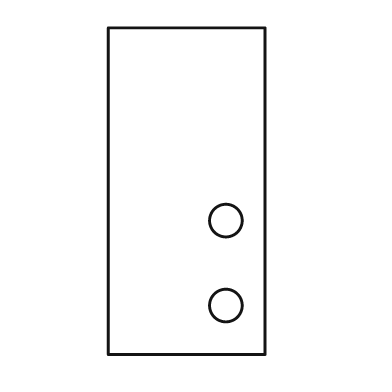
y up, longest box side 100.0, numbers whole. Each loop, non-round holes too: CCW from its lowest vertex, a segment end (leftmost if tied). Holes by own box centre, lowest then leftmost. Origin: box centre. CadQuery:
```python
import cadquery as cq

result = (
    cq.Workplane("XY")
    .moveTo(-24.0, -50.0)
    .lineTo(24.0, -50.0)
    .lineTo(24.0, 50.0)
    .lineTo(-24.0, 50.0)
    .close()
    .moveTo(12.0, -35.0)
    .circle(5.0)
    .moveTo(12.0, -9.0)
    .circle(5.0)
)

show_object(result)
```